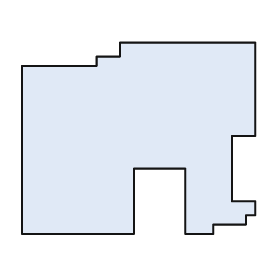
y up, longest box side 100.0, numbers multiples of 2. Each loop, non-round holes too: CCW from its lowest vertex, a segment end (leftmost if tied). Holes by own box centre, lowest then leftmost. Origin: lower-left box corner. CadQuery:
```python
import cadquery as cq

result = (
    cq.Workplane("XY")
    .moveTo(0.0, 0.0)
    .lineTo(48.0, 0.0)
    .lineTo(48.0, 28.0)
    .lineTo(70.0, 28.0)
    .lineTo(70.0, 0.0)
    .lineTo(82.0, 0.0)
    .lineTo(82.0, 4.0)
    .lineTo(96.0, 4.0)
    .lineTo(96.0, 8.0)
    .lineTo(100.0, 8.0)
    .lineTo(100.0, 14.0)
    .lineTo(90.0, 14.0)
    .lineTo(90.0, 42.0)
    .lineTo(100.0, 42.0)
    .lineTo(100.0, 82.0)
    .lineTo(42.0, 82.0)
    .lineTo(42.0, 76.0)
    .lineTo(32.0, 76.0)
    .lineTo(32.0, 72.0)
    .lineTo(0.0, 72.0)
    .close()
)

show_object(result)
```